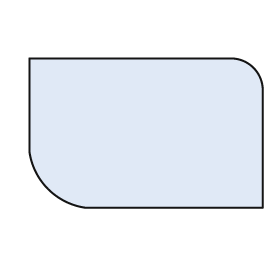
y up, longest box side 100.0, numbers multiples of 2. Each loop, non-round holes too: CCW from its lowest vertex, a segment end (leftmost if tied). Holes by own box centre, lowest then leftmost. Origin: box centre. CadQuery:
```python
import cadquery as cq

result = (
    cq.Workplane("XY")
    .moveTo(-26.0, -32.0)
    .lineTo(50.0, -32.0)
    .lineTo(50.0, 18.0)
    .threePointArc((46.0, 28.0), (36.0, 32.0))
    .lineTo(-50.0, 32.0)
    .lineTo(-50.0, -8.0)
    .threePointArc((-42.0, -24.0), (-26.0, -32.0))
    .close()
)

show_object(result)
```